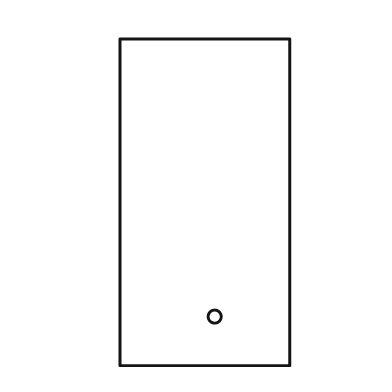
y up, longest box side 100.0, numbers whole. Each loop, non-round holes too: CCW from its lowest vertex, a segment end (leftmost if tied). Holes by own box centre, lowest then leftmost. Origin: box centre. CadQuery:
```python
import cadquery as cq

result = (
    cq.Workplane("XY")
    .moveTo(-26.0, -50.0)
    .lineTo(26.0, -50.0)
    .lineTo(26.0, 50.0)
    .lineTo(-26.0, 50.0)
    .close()
    .moveTo(3.0, -35.0)
    .circle(2.0)
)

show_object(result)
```